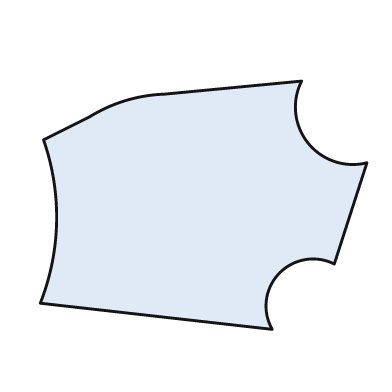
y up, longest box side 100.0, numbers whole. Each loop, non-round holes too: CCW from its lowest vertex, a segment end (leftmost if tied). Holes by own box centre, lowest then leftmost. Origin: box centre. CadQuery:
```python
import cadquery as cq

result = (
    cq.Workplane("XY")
    .moveTo(21.0, -38.0)
    .threePointArc((23.0, -21.0), (40.0, -18.0))
    .lineTo(50.0, 13.0)
    .threePointArc((32.0, 19.0), (30.0, 38.0))
    .lineTo(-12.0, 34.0)
    .threePointArc((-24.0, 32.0), (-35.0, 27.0))
    .lineTo(-49.0, 20.0)
    .threePointArc((-45.0, -5.0), (-50.0, -30.0))
    .close()
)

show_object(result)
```